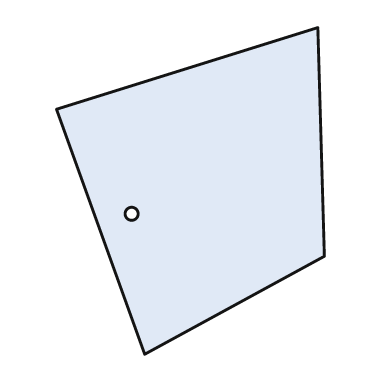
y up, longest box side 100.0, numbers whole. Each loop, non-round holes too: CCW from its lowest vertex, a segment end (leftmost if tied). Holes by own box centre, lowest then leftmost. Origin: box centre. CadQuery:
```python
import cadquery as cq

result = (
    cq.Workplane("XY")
    .moveTo(-14.0, -50.0)
    .lineTo(41.0, -20.0)
    .lineTo(39.0, 50.0)
    .lineTo(-41.0, 25.0)
    .close()
    .moveTo(-18.0, -7.0)
    .circle(2.0)
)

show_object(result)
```